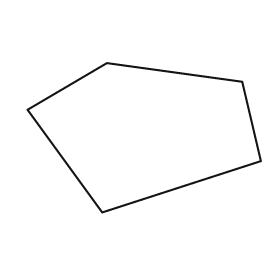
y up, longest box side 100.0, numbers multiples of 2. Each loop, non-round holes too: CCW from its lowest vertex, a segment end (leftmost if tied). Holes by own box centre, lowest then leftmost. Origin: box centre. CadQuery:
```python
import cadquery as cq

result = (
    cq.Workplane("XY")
    .moveTo(-18.0, -32.0)
    .lineTo(50.0, -10.0)
    .lineTo(42.0, 24.0)
    .lineTo(-16.0, 32.0)
    .lineTo(-50.0, 12.0)
    .close()
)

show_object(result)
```